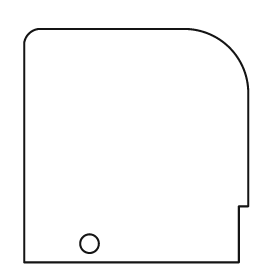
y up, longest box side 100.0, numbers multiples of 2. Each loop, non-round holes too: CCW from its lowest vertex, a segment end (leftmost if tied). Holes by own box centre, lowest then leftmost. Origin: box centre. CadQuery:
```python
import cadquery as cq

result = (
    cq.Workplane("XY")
    .moveTo(-48.0, -50.0)
    .lineTo(44.0, -50.0)
    .lineTo(44.0, -26.0)
    .lineTo(48.0, -26.0)
    .lineTo(48.0, 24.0)
    .threePointArc((40.0, 42.0), (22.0, 50.0))
    .lineTo(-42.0, 50.0)
    .threePointArc((-46.0, 48.0), (-48.0, 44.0))
    .close()
    .moveTo(-20.0, -42.0)
    .circle(4.0)
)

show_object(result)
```